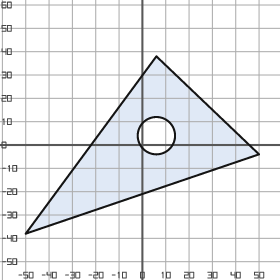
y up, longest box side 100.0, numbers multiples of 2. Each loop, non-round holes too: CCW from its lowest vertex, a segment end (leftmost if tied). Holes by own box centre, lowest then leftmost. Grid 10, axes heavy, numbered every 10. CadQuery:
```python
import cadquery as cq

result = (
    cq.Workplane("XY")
    .moveTo(-50.0, -38.0)
    .lineTo(50.0, -4.0)
    .lineTo(6.0, 38.0)
    .close()
    .moveTo(6.0, 4.0)
    .circle(8.0)
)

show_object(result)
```